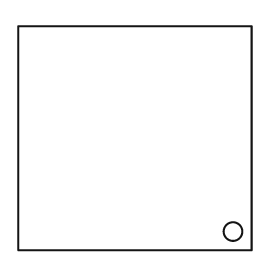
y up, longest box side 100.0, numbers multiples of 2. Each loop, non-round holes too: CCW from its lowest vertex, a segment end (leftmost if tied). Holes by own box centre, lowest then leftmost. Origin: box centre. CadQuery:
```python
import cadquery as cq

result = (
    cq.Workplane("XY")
    .moveTo(-50.0, -48.0)
    .lineTo(50.0, -48.0)
    .lineTo(50.0, 48.0)
    .lineTo(-50.0, 48.0)
    .close()
    .moveTo(42.0, -40.0)
    .circle(4.0)
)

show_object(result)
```